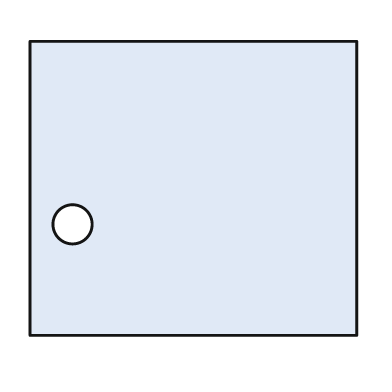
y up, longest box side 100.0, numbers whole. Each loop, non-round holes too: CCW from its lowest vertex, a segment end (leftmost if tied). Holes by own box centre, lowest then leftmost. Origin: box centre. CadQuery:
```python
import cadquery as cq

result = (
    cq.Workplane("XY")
    .moveTo(-50.0, -45.0)
    .lineTo(50.0, -45.0)
    .lineTo(50.0, 45.0)
    .lineTo(-50.0, 45.0)
    .close()
    .moveTo(-37.0, -11.0)
    .circle(6.0)
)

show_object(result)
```